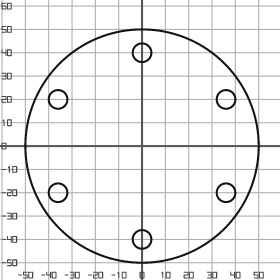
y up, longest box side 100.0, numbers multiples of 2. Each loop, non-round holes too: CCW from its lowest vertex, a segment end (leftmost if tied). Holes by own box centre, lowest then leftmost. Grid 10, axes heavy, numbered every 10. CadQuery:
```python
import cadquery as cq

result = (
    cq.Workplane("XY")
    .moveTo(0.0, 0.0)
    .circle(50.0)
    .moveTo(0.0, -40.0)
    .circle(4.0)
    .moveTo(-36.0, -20.0)
    .circle(4.0)
    .moveTo(36.0, -20.0)
    .circle(4.0)
    .moveTo(-36.0, 20.0)
    .circle(4.0)
    .moveTo(36.0, 20.0)
    .circle(4.0)
    .moveTo(0.0, 40.0)
    .circle(4.0)
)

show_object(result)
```